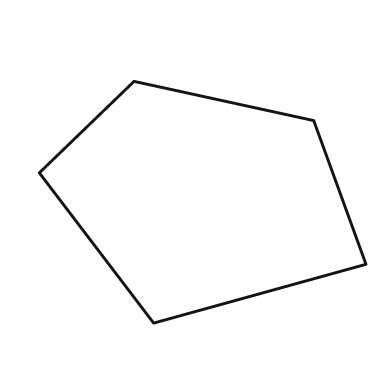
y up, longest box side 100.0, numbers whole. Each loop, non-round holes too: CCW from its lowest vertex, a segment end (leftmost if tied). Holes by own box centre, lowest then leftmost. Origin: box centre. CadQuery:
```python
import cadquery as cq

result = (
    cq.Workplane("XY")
    .moveTo(-15.0, -37.0)
    .lineTo(50.0, -19.0)
    .lineTo(34.0, 25.0)
    .lineTo(-21.0, 37.0)
    .lineTo(-50.0, 9.0)
    .close()
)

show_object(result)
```